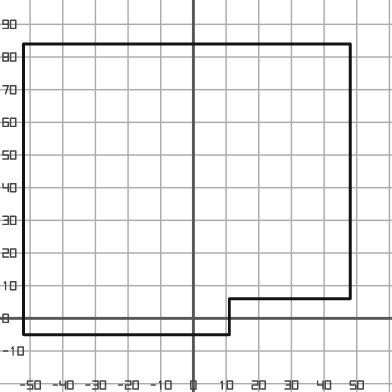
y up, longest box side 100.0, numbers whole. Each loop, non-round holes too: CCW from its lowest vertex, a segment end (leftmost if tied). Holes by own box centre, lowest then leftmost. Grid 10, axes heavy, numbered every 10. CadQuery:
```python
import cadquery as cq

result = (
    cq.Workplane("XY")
    .moveTo(-52.0, -5.0)
    .lineTo(11.0, -5.0)
    .lineTo(11.0, 6.0)
    .lineTo(48.0, 6.0)
    .lineTo(48.0, 84.0)
    .lineTo(-52.0, 84.0)
    .close()
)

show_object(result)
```